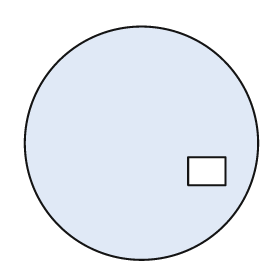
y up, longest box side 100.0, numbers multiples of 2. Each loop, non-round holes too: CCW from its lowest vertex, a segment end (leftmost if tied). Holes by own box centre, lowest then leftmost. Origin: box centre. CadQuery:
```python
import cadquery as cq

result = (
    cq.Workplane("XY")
    .moveTo(0.0, 0.0)
    .circle(50.0)
    .moveTo(20.0, -18.0)
    .lineTo(36.0, -18.0)
    .lineTo(36.0, -6.0)
    .lineTo(20.0, -6.0)
    .close()
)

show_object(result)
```